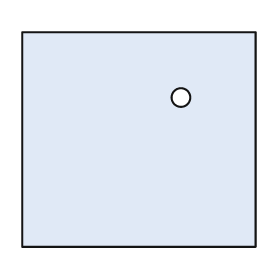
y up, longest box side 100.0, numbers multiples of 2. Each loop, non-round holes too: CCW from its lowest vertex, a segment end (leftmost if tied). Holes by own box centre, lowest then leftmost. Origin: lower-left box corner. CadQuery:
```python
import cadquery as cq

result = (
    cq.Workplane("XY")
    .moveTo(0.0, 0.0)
    .lineTo(100.0, 0.0)
    .lineTo(100.0, 92.0)
    .lineTo(0.0, 92.0)
    .close()
    .moveTo(68.0, 64.0)
    .circle(4.0)
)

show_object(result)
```